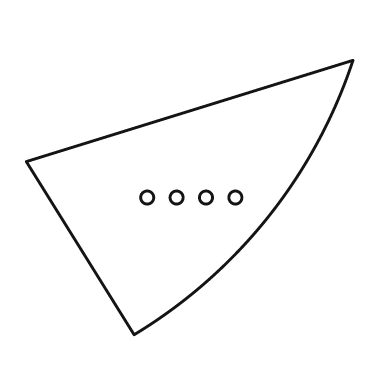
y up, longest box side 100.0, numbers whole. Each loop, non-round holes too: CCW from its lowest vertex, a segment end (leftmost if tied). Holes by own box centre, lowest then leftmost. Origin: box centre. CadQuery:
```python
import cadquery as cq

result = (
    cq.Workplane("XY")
    .moveTo(-17.0, -42.0)
    .threePointArc((24.0, -6.0), (50.0, 42.0))
    .lineTo(-50.0, 11.0)
    .close()
    .moveTo(-13.0, 0.0)
    .circle(2.0)
    .moveTo(-4.0, 0.0)
    .circle(2.0)
    .moveTo(5.0, 0.0)
    .circle(2.0)
    .moveTo(14.0, 0.0)
    .circle(2.0)
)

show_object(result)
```